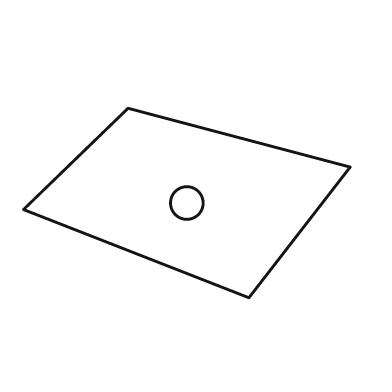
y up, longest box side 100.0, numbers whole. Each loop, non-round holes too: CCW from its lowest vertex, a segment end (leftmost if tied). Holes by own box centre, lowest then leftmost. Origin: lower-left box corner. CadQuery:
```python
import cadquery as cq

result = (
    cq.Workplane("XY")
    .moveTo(69.0, 0.0)
    .lineTo(100.0, 40.0)
    .lineTo(32.0, 58.0)
    .lineTo(0.0, 27.0)
    .close()
    .moveTo(50.0, 29.0)
    .circle(5.0)
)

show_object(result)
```